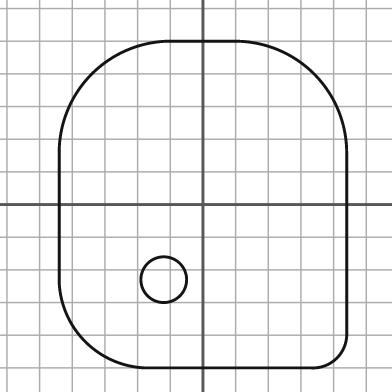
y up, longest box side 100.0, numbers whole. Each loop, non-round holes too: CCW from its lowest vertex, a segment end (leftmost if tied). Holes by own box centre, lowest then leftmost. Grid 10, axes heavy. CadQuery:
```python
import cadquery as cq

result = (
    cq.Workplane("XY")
    .moveTo(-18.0, -50.0)
    .lineTo(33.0, -50.0)
    .threePointArc((41.0, -47.0), (44.0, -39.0))
    .lineTo(44.0, 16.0)
    .threePointArc((34.0, 40.0), (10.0, 50.0))
    .lineTo(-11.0, 50.0)
    .threePointArc((-34.0, 40.0), (-44.0, 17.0))
    .lineTo(-44.0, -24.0)
    .threePointArc((-36.0, -42.0), (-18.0, -50.0))
    .close()
    .moveTo(-12.0, -23.0)
    .circle(7.0)
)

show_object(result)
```